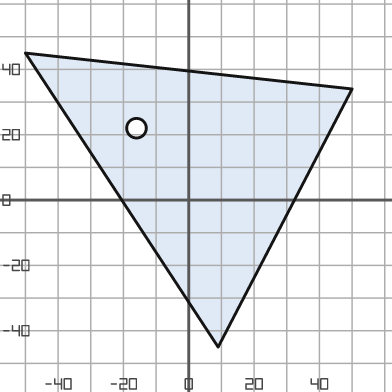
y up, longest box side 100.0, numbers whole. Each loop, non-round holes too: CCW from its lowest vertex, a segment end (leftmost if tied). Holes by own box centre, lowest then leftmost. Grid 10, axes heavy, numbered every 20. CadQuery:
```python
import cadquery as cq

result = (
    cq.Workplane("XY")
    .moveTo(9.0, -45.0)
    .lineTo(50.0, 34.0)
    .lineTo(-50.0, 45.0)
    .close()
    .moveTo(-16.0, 22.0)
    .circle(3.0)
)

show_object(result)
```